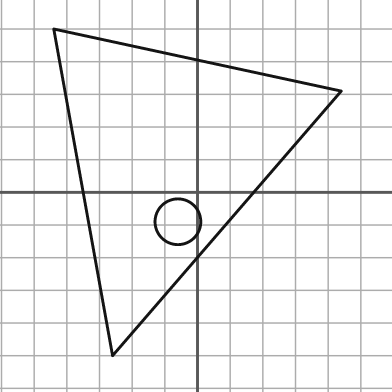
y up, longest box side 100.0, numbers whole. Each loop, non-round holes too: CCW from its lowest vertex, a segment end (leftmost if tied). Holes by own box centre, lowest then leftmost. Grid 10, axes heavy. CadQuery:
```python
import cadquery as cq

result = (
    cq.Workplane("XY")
    .moveTo(-26.0, -50.0)
    .lineTo(44.0, 31.0)
    .lineTo(-44.0, 50.0)
    .close()
    .moveTo(-6.0, -9.0)
    .circle(7.0)
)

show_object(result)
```